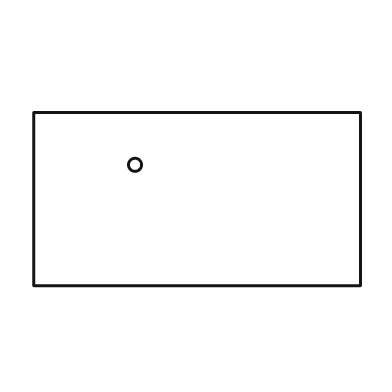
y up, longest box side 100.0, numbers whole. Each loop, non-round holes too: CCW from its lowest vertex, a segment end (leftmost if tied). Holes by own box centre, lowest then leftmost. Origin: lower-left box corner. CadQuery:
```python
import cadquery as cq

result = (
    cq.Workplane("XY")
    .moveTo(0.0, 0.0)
    .lineTo(100.0, 0.0)
    .lineTo(100.0, 53.0)
    .lineTo(0.0, 53.0)
    .close()
    .moveTo(31.0, 37.0)
    .circle(2.0)
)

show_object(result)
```